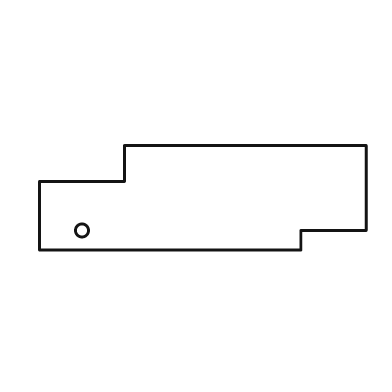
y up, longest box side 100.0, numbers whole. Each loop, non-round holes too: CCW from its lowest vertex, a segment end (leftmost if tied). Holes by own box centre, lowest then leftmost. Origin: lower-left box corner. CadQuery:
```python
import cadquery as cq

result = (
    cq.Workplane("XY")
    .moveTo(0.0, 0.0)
    .lineTo(80.0, 0.0)
    .lineTo(80.0, 6.0)
    .lineTo(100.0, 6.0)
    .lineTo(100.0, 32.0)
    .lineTo(26.0, 32.0)
    .lineTo(26.0, 21.0)
    .lineTo(0.0, 21.0)
    .close()
    .moveTo(13.0, 6.0)
    .circle(2.0)
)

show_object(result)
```